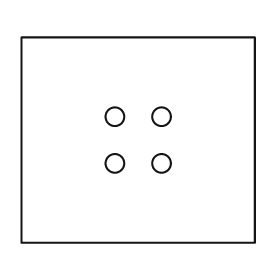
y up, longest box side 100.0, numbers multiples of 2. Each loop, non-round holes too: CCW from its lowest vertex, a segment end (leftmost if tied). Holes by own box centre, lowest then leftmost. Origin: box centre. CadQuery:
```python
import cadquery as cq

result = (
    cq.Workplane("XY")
    .moveTo(-50.0, -44.0)
    .lineTo(50.0, -44.0)
    .lineTo(50.0, 44.0)
    .lineTo(-50.0, 44.0)
    .close()
    .moveTo(-10.0, -10.0)
    .circle(4.0)
    .moveTo(10.0, -10.0)
    .circle(4.0)
    .moveTo(-10.0, 10.0)
    .circle(4.0)
    .moveTo(10.0, 10.0)
    .circle(4.0)
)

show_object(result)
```